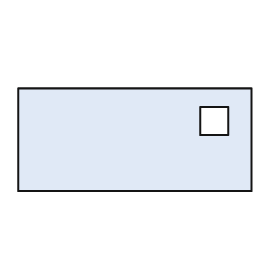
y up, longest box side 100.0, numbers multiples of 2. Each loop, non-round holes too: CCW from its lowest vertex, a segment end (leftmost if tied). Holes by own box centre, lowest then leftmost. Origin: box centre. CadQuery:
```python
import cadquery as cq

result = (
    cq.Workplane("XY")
    .moveTo(-50.0, -22.0)
    .lineTo(50.0, -22.0)
    .lineTo(50.0, 22.0)
    .lineTo(-50.0, 22.0)
    .close()
    .moveTo(28.0, 2.0)
    .lineTo(40.0, 2.0)
    .lineTo(40.0, 14.0)
    .lineTo(28.0, 14.0)
    .close()
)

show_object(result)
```